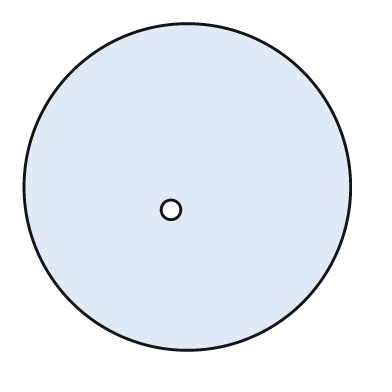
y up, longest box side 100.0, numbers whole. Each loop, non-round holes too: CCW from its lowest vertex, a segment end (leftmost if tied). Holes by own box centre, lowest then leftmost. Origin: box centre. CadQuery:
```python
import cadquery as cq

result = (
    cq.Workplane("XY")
    .moveTo(0.0, 0.0)
    .circle(50.0)
    .moveTo(-5.0, -7.0)
    .circle(3.0)
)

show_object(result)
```